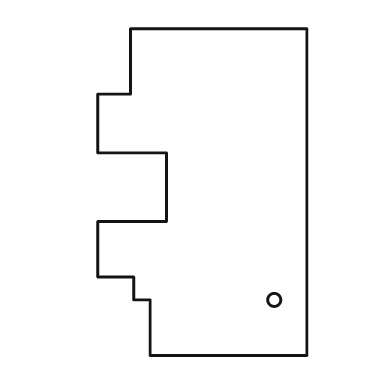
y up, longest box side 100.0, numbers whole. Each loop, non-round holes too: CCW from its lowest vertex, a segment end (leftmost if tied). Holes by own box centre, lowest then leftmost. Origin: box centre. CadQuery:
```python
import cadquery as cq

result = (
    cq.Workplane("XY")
    .moveTo(-16.0, -50.0)
    .lineTo(32.0, -50.0)
    .lineTo(32.0, 50.0)
    .lineTo(-22.0, 50.0)
    .lineTo(-22.0, 30.0)
    .lineTo(-32.0, 30.0)
    .lineTo(-32.0, 12.0)
    .lineTo(-11.0, 12.0)
    .lineTo(-11.0, -9.0)
    .lineTo(-32.0, -9.0)
    .lineTo(-32.0, -26.0)
    .lineTo(-21.0, -26.0)
    .lineTo(-21.0, -33.0)
    .lineTo(-16.0, -33.0)
    .close()
    .moveTo(22.0, -33.0)
    .circle(2.0)
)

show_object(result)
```